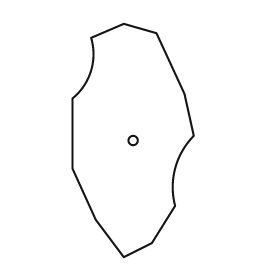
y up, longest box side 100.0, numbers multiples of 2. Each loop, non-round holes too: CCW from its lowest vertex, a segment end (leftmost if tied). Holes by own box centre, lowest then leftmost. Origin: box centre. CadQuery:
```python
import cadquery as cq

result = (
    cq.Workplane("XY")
    .moveTo(-4.0, -50.0)
    .lineTo(8.0, -44.0)
    .lineTo(18.0, -28.0)
    .threePointArc((18.0, -12.0), (26.0, 2.0))
    .lineTo(22.0, 20.0)
    .lineTo(10.0, 46.0)
    .lineTo(-4.0, 50.0)
    .lineTo(-18.0, 44.0)
    .threePointArc((-18.0, 30.0), (-26.0, 18.0))
    .lineTo(-26.0, -12.0)
    .lineTo(-16.0, -34.0)
    .close()
    .moveTo(0.0, 0.0)
    .circle(2.0)
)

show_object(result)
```